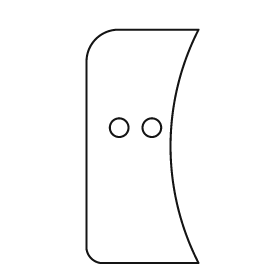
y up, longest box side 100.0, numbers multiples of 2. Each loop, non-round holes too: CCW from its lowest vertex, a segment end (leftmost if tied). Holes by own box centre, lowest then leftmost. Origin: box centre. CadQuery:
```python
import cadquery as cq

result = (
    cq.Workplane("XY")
    .moveTo(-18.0, -50.0)
    .lineTo(24.0, -50.0)
    .threePointArc((12.0, 0.0), (24.0, 50.0))
    .lineTo(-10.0, 50.0)
    .threePointArc((-20.0, 46.0), (-24.0, 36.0))
    .lineTo(-24.0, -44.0)
    .threePointArc((-22.0, -48.0), (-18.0, -50.0))
    .close()
    .moveTo(-10.0, 8.0)
    .circle(4.0)
    .moveTo(4.0, 8.0)
    .circle(4.0)
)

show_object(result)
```